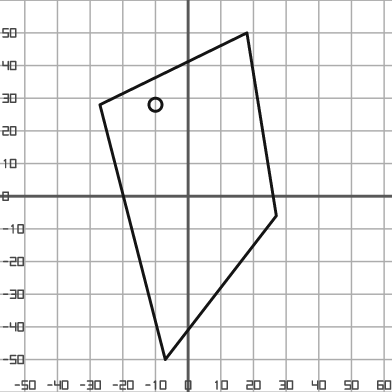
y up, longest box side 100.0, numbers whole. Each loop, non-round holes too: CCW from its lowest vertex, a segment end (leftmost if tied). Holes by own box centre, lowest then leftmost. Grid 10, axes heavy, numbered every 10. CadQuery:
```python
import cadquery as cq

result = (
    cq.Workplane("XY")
    .moveTo(-7.0, -50.0)
    .lineTo(27.0, -6.0)
    .lineTo(18.0, 50.0)
    .lineTo(-27.0, 28.0)
    .close()
    .moveTo(-10.0, 28.0)
    .circle(2.0)
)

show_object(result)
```